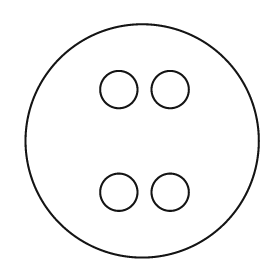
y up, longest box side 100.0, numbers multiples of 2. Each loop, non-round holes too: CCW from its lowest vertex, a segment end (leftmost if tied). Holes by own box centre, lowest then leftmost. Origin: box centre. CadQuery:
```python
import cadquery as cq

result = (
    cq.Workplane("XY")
    .moveTo(0.0, 0.0)
    .circle(50.0)
    .moveTo(-10.0, -22.0)
    .circle(8.0)
    .moveTo(12.0, -22.0)
    .circle(8.0)
    .moveTo(-10.0, 22.0)
    .circle(8.0)
    .moveTo(12.0, 22.0)
    .circle(8.0)
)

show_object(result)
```